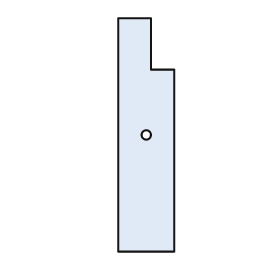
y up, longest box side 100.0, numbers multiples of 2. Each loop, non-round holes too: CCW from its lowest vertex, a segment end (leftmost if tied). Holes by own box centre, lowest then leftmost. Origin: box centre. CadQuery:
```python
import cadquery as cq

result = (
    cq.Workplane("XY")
    .moveTo(-12.0, -50.0)
    .lineTo(12.0, -50.0)
    .lineTo(12.0, 28.0)
    .lineTo(2.0, 28.0)
    .lineTo(2.0, 50.0)
    .lineTo(-12.0, 50.0)
    .close()
    .moveTo(0.0, 0.0)
    .circle(2.0)
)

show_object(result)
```